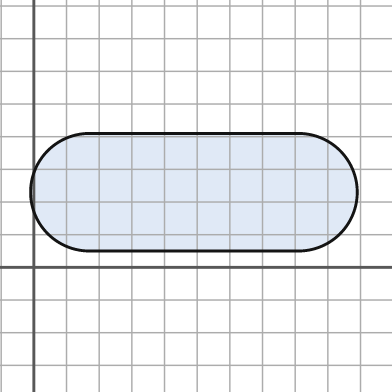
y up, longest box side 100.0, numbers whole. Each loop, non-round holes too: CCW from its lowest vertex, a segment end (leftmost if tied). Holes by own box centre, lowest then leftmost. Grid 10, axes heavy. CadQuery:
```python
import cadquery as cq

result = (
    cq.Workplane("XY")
    .moveTo(17.0, 5.0)
    .lineTo(81.0, 5.0)
    .threePointArc((99.0, 23.0), (81.0, 41.0))
    .lineTo(17.0, 41.0)
    .threePointArc((-1.0, 23.0), (17.0, 5.0))
    .close()
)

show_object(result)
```